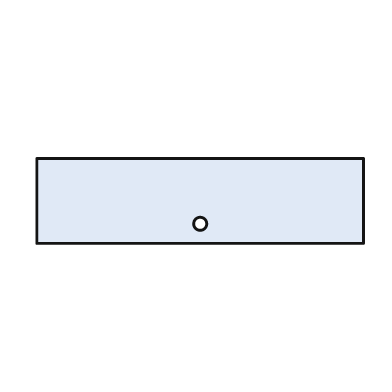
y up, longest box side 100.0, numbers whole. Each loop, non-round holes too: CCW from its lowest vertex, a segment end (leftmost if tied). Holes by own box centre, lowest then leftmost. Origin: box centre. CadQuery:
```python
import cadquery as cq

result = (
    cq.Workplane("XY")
    .moveTo(-50.0, -13.0)
    .lineTo(50.0, -13.0)
    .lineTo(50.0, 13.0)
    .lineTo(-50.0, 13.0)
    .close()
    .moveTo(0.0, -7.0)
    .circle(2.0)
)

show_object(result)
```